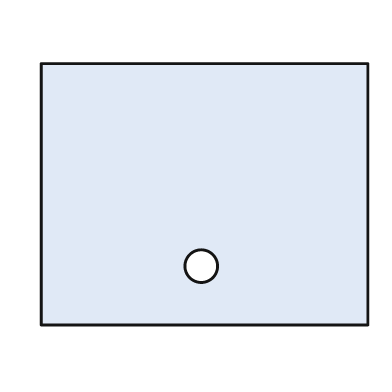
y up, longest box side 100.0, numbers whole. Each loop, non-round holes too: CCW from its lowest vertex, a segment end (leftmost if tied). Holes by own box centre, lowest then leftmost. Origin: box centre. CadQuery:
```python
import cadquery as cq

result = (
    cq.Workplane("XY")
    .moveTo(-50.0, -40.0)
    .lineTo(50.0, -40.0)
    .lineTo(50.0, 40.0)
    .lineTo(-50.0, 40.0)
    .close()
    .moveTo(-1.0, -22.0)
    .circle(5.0)
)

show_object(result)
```